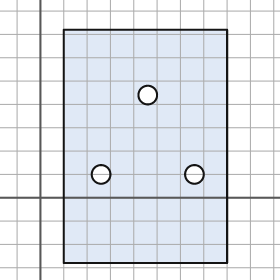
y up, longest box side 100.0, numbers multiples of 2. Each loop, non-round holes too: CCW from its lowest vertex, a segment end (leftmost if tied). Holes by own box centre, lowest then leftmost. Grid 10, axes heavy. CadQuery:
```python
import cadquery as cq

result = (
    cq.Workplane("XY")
    .moveTo(10.0, -28.0)
    .lineTo(80.0, -28.0)
    .lineTo(80.0, 72.0)
    .lineTo(10.0, 72.0)
    .close()
    .moveTo(26.0, 10.0)
    .circle(4.0)
    .moveTo(66.0, 10.0)
    .circle(4.0)
    .moveTo(46.0, 44.0)
    .circle(4.0)
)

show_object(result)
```